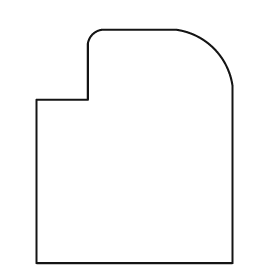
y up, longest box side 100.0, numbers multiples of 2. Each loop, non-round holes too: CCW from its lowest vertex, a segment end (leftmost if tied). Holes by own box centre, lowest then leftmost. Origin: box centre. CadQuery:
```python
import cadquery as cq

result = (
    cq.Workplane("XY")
    .moveTo(-42.0, -50.0)
    .lineTo(42.0, -50.0)
    .lineTo(42.0, 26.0)
    .threePointArc((34.0, 42.0), (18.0, 50.0))
    .lineTo(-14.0, 50.0)
    .threePointArc((-18.0, 48.0), (-20.0, 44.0))
    .lineTo(-20.0, 20.0)
    .lineTo(-42.0, 20.0)
    .close()
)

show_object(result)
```